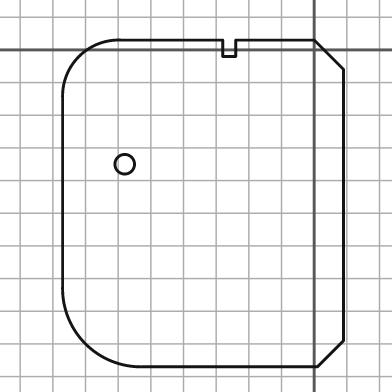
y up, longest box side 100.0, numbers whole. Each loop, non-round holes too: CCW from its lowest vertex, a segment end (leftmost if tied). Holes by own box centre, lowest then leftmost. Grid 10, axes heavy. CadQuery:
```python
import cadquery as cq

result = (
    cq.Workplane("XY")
    .moveTo(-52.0, -97.0)
    .lineTo(1.0, -97.0)
    .lineTo(9.0, -89.0)
    .lineTo(9.0, -6.0)
    .lineTo(0.0, 3.0)
    .lineTo(-24.0, 3.0)
    .lineTo(-24.0, -2.0)
    .lineTo(-28.0, -2.0)
    .lineTo(-28.0, 3.0)
    .lineTo(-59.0, 3.0)
    .threePointArc((-72.0, -2.0), (-77.0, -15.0))
    .lineTo(-77.0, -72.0)
    .threePointArc((-70.0, -90.0), (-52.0, -97.0))
    .close()
    .moveTo(-58.0, -35.0)
    .circle(3.0)
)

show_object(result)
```